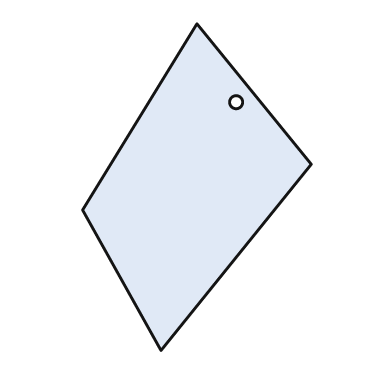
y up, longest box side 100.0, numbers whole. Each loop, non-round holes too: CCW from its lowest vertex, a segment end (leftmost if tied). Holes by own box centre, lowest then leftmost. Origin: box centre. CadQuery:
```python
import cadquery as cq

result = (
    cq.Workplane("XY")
    .moveTo(-11.0, -50.0)
    .lineTo(35.0, 7.0)
    .lineTo(0.0, 50.0)
    .lineTo(-35.0, -7.0)
    .close()
    .moveTo(12.0, 26.0)
    .circle(2.0)
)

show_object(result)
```